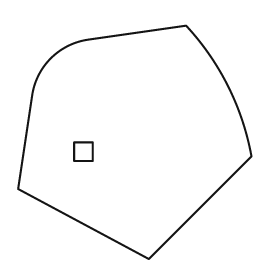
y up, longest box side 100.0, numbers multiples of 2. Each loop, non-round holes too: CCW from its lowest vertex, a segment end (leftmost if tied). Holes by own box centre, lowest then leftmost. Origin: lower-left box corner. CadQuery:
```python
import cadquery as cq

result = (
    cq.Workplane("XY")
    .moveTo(56.0, 0.0)
    .lineTo(100.0, 44.0)
    .threePointArc((90.0, 74.0), (72.0, 100.0))
    .lineTo(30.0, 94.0)
    .threePointArc((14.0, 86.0), (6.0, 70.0))
    .lineTo(0.0, 30.0)
    .close()
    .moveTo(24.0, 42.0)
    .lineTo(32.0, 42.0)
    .lineTo(32.0, 50.0)
    .lineTo(24.0, 50.0)
    .close()
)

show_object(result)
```